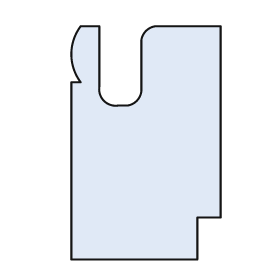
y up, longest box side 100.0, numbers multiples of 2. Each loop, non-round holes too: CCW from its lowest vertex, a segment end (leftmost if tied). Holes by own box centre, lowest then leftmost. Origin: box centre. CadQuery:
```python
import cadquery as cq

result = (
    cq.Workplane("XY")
    .moveTo(-32.0, -50.0)
    .lineTo(22.0, -50.0)
    .lineTo(22.0, -32.0)
    .lineTo(32.0, -32.0)
    .lineTo(32.0, 50.0)
    .lineTo(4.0, 50.0)
    .threePointArc((0.0, 48.0), (-2.0, 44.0))
    .lineTo(-2.0, 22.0)
    .threePointArc((-4.0, 18.0), (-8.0, 16.0))
    .lineTo(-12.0, 16.0)
    .threePointArc((-18.0, 18.0), (-20.0, 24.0))
    .lineTo(-20.0, 50.0)
    .lineTo(-28.0, 50.0)
    .threePointArc((-32.0, 38.0), (-28.0, 26.0))
    .lineTo(-32.0, 26.0)
    .close()
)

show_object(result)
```